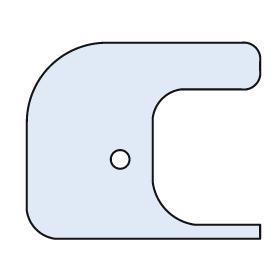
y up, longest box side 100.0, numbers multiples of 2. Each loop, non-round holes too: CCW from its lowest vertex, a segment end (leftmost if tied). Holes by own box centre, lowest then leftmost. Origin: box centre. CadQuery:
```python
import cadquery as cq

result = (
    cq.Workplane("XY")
    .moveTo(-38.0, -42.0)
    .lineTo(50.0, -42.0)
    .lineTo(50.0, -36.0)
    .lineTo(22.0, -36.0)
    .threePointArc((10.0, -30.0), (4.0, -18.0))
    .lineTo(4.0, 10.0)
    .threePointArc((8.0, 18.0), (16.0, 22.0))
    .lineTo(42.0, 22.0)
    .threePointArc((48.0, 24.0), (50.0, 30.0))
    .lineTo(50.0, 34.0)
    .threePointArc((48.0, 40.0), (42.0, 42.0))
    .lineTo(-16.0, 42.0)
    .threePointArc((-40.0, 32.0), (-50.0, 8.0))
    .lineTo(-50.0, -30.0)
    .threePointArc((-46.0, -38.0), (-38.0, -42.0))
    .close()
    .moveTo(-10.0, -8.0)
    .circle(4.0)
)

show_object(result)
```